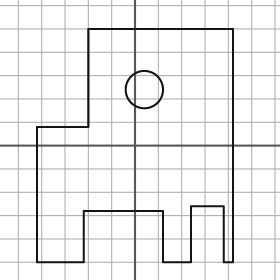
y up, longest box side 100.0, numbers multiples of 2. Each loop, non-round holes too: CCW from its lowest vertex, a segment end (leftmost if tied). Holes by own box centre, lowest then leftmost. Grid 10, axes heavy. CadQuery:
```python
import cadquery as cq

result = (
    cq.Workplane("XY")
    .moveTo(-42.0, -50.0)
    .lineTo(-22.0, -50.0)
    .lineTo(-22.0, -28.0)
    .lineTo(12.0, -28.0)
    .lineTo(12.0, -50.0)
    .lineTo(24.0, -50.0)
    .lineTo(24.0, -26.0)
    .lineTo(38.0, -26.0)
    .lineTo(38.0, -50.0)
    .lineTo(42.0, -50.0)
    .lineTo(42.0, 50.0)
    .lineTo(-20.0, 50.0)
    .lineTo(-20.0, 8.0)
    .lineTo(-42.0, 8.0)
    .close()
    .moveTo(4.0, 24.0)
    .circle(8.0)
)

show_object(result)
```